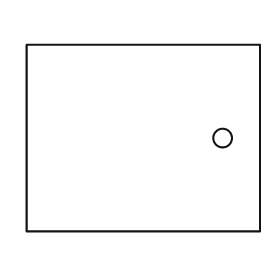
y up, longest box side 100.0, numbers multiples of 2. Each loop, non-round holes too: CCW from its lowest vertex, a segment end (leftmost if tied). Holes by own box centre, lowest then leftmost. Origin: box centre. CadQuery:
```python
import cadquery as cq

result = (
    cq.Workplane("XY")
    .moveTo(-50.0, -40.0)
    .lineTo(50.0, -40.0)
    .lineTo(50.0, 40.0)
    .lineTo(-50.0, 40.0)
    .close()
    .moveTo(34.0, 0.0)
    .circle(4.0)
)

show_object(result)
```